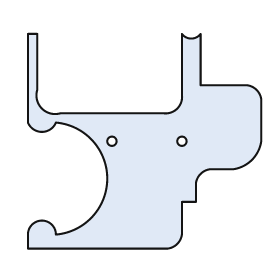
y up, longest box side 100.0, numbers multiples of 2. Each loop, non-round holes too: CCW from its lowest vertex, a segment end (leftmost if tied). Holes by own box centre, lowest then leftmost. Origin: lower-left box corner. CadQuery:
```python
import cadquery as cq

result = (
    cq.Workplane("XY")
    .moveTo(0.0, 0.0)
    .lineTo(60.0, 0.0)
    .threePointArc((64.0, 2.0), (66.0, 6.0))
    .lineTo(66.0, 20.0)
    .lineTo(72.0, 20.0)
    .lineTo(72.0, 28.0)
    .threePointArc((74.0, 32.0), (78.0, 34.0))
    .lineTo(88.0, 34.0)
    .threePointArc((96.0, 38.0), (100.0, 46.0))
    .lineTo(100.0, 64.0)
    .threePointArc((98.0, 68.0), (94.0, 70.0))
    .lineTo(74.0, 70.0)
    .lineTo(74.0, 92.0)
    .threePointArc((70.0, 90.0), (66.0, 92.0))
    .lineTo(66.0, 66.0)
    .threePointArc((64.0, 60.0), (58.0, 58.0))
    .lineTo(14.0, 58.0)
    .threePointArc((6.0, 60.0), (4.0, 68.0))
    .lineTo(4.0, 92.0)
    .lineTo(0.0, 92.0)
    .lineTo(0.0, 54.0)
    .threePointArc((6.0, 50.0), (12.0, 54.0))
    .threePointArc((34.0, 30.0), (12.0, 6.0))
    .threePointArc((6.0, 12.0), (0.0, 6.0))
    .close()
    .moveTo(36.0, 46.0)
    .circle(2.0)
    .moveTo(66.0, 46.0)
    .circle(2.0)
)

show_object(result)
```